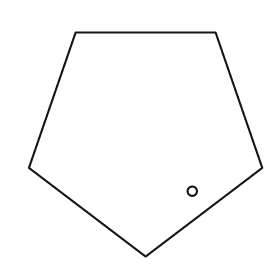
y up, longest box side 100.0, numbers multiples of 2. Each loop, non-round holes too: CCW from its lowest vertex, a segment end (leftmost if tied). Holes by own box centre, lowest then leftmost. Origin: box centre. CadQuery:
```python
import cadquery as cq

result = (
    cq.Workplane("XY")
    .moveTo(0.0, -48.0)
    .lineTo(50.0, -10.0)
    .lineTo(30.0, 48.0)
    .lineTo(-30.0, 48.0)
    .lineTo(-50.0, -10.0)
    .close()
    .moveTo(20.0, -20.0)
    .circle(2.0)
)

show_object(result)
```